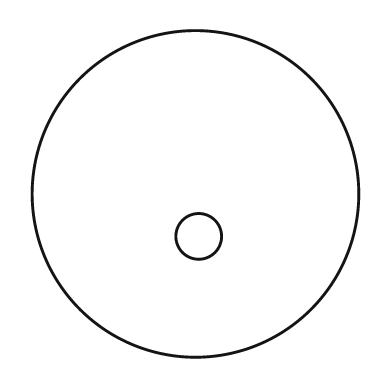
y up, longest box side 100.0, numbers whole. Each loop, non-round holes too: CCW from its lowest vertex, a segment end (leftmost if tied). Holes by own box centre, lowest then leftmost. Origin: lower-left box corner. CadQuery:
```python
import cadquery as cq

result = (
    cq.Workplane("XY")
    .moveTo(50.0, 50.0)
    .circle(50.0)
    .moveTo(51.0, 37.0)
    .circle(7.0)
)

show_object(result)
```